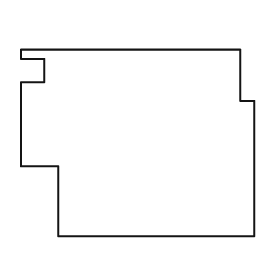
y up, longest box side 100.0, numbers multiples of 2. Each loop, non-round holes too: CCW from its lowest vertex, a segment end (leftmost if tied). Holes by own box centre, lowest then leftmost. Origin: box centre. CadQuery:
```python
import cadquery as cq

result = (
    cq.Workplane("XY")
    .moveTo(-34.0, -40.0)
    .lineTo(50.0, -40.0)
    .lineTo(50.0, 18.0)
    .lineTo(44.0, 18.0)
    .lineTo(44.0, 40.0)
    .lineTo(-50.0, 40.0)
    .lineTo(-50.0, 36.0)
    .lineTo(-40.0, 36.0)
    .lineTo(-40.0, 26.0)
    .lineTo(-50.0, 26.0)
    .lineTo(-50.0, -10.0)
    .lineTo(-34.0, -10.0)
    .close()
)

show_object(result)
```